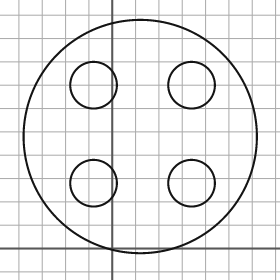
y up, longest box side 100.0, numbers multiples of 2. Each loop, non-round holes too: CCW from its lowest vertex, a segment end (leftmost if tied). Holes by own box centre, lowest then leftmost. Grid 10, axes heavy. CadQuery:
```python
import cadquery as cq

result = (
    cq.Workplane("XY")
    .moveTo(12.0, 48.0)
    .circle(50.0)
    .moveTo(-8.0, 28.0)
    .circle(10.0)
    .moveTo(34.0, 28.0)
    .circle(10.0)
    .moveTo(-8.0, 70.0)
    .circle(10.0)
    .moveTo(34.0, 70.0)
    .circle(10.0)
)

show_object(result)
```